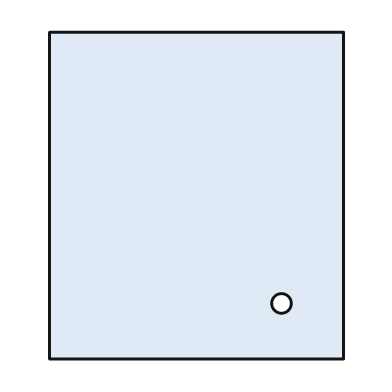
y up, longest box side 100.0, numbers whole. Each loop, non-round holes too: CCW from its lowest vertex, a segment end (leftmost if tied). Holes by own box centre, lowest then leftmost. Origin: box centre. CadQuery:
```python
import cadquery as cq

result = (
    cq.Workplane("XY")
    .moveTo(-45.0, -50.0)
    .lineTo(45.0, -50.0)
    .lineTo(45.0, 50.0)
    .lineTo(-45.0, 50.0)
    .close()
    .moveTo(26.0, -33.0)
    .circle(3.0)
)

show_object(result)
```